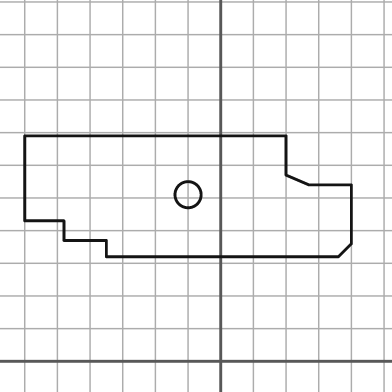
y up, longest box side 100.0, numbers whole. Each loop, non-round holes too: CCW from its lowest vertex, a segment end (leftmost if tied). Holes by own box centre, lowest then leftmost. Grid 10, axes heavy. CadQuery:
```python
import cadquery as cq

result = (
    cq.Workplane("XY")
    .moveTo(-35.0, 32.0)
    .lineTo(36.0, 32.0)
    .lineTo(40.0, 36.0)
    .lineTo(40.0, 54.0)
    .lineTo(27.0, 54.0)
    .lineTo(20.0, 57.0)
    .lineTo(20.0, 69.0)
    .lineTo(-60.0, 69.0)
    .lineTo(-60.0, 43.0)
    .lineTo(-48.0, 43.0)
    .lineTo(-48.0, 37.0)
    .lineTo(-35.0, 37.0)
    .close()
    .moveTo(-10.0, 51.0)
    .circle(4.0)
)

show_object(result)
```